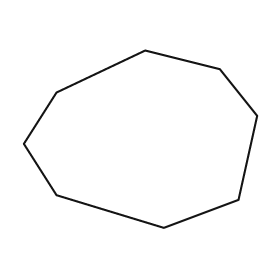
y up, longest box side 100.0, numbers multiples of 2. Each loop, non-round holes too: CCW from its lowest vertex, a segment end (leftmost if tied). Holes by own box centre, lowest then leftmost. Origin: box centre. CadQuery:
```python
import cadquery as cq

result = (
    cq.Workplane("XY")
    .moveTo(10.0, -38.0)
    .lineTo(42.0, -26.0)
    .lineTo(50.0, 10.0)
    .lineTo(34.0, 30.0)
    .lineTo(2.0, 38.0)
    .lineTo(-36.0, 20.0)
    .lineTo(-50.0, -2.0)
    .lineTo(-36.0, -24.0)
    .close()
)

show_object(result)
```